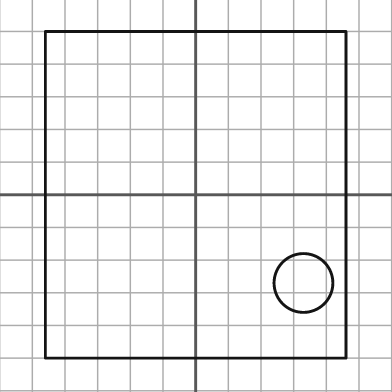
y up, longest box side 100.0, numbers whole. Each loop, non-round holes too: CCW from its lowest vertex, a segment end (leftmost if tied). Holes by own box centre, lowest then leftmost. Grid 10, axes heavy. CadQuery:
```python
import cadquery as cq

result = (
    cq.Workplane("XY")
    .moveTo(-46.0, -50.0)
    .lineTo(46.0, -50.0)
    .lineTo(46.0, 50.0)
    .lineTo(-46.0, 50.0)
    .close()
    .moveTo(33.0, -27.0)
    .circle(9.0)
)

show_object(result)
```